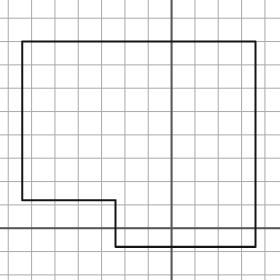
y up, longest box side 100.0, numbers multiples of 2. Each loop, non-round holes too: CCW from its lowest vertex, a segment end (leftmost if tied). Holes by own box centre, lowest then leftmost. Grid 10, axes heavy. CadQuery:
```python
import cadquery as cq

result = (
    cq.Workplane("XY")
    .moveTo(-24.0, -8.0)
    .lineTo(36.0, -8.0)
    .lineTo(36.0, 80.0)
    .lineTo(-64.0, 80.0)
    .lineTo(-64.0, 12.0)
    .lineTo(-24.0, 12.0)
    .close()
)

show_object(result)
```